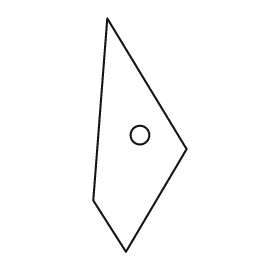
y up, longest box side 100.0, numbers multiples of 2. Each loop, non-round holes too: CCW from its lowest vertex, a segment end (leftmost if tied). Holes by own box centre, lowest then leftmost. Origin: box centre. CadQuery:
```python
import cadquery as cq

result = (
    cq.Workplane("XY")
    .moveTo(-6.0, -50.0)
    .lineTo(20.0, -6.0)
    .lineTo(-14.0, 50.0)
    .lineTo(-20.0, -28.0)
    .close()
    .moveTo(0.0, 0.0)
    .circle(4.0)
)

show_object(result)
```